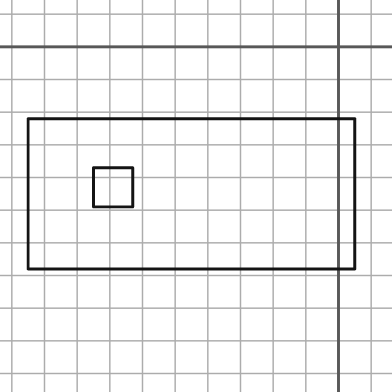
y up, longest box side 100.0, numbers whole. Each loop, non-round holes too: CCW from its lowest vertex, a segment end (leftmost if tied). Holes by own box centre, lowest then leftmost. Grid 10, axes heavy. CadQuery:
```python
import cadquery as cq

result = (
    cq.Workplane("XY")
    .moveTo(-95.0, -68.0)
    .lineTo(5.0, -68.0)
    .lineTo(5.0, -22.0)
    .lineTo(-95.0, -22.0)
    .close()
    .moveTo(-75.0, -49.0)
    .lineTo(-63.0, -49.0)
    .lineTo(-63.0, -37.0)
    .lineTo(-75.0, -37.0)
    .close()
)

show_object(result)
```